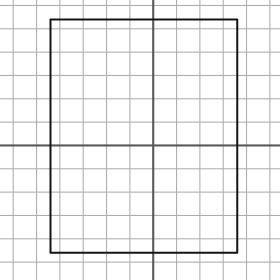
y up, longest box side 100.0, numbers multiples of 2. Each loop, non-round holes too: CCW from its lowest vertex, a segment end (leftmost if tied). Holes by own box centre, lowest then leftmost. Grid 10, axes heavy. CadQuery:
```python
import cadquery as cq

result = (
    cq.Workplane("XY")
    .moveTo(-44.0, -46.0)
    .lineTo(36.0, -46.0)
    .lineTo(36.0, 54.0)
    .lineTo(-44.0, 54.0)
    .close()
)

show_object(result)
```